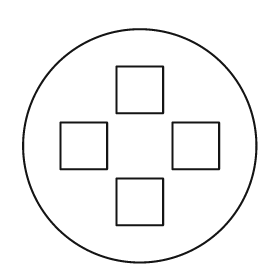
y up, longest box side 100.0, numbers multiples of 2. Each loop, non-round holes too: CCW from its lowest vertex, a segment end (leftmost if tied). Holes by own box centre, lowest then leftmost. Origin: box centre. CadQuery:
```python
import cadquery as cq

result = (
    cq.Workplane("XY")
    .moveTo(0.0, 0.0)
    .circle(50.0)
    .moveTo(-10.0, -34.0)
    .lineTo(10.0, -34.0)
    .lineTo(10.0, -14.0)
    .lineTo(-10.0, -14.0)
    .close()
    .moveTo(-34.0, -10.0)
    .lineTo(-14.0, -10.0)
    .lineTo(-14.0, 10.0)
    .lineTo(-34.0, 10.0)
    .close()
    .moveTo(14.0, -10.0)
    .lineTo(34.0, -10.0)
    .lineTo(34.0, 10.0)
    .lineTo(14.0, 10.0)
    .close()
    .moveTo(-10.0, 14.0)
    .lineTo(10.0, 14.0)
    .lineTo(10.0, 34.0)
    .lineTo(-10.0, 34.0)
    .close()
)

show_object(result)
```